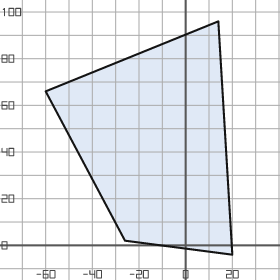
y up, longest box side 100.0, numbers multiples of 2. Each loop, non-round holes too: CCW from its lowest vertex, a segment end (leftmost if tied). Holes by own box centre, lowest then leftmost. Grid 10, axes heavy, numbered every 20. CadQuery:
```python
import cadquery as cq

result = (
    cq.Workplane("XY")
    .moveTo(20.0, -4.0)
    .lineTo(14.0, 96.0)
    .lineTo(-60.0, 66.0)
    .lineTo(-26.0, 2.0)
    .close()
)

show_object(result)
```